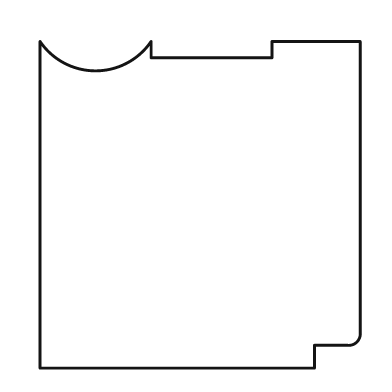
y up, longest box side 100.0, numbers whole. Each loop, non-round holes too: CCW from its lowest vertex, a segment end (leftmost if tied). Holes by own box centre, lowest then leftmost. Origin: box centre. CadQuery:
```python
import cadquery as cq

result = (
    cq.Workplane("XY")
    .moveTo(-49.0, -50.0)
    .lineTo(35.0, -50.0)
    .lineTo(35.0, -43.0)
    .lineTo(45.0, -43.0)
    .threePointArc((48.0, -42.0), (49.0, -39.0))
    .lineTo(49.0, 50.0)
    .lineTo(22.0, 50.0)
    .lineTo(22.0, 45.0)
    .lineTo(-15.0, 45.0)
    .lineTo(-15.0, 50.0)
    .threePointArc((-32.0, 41.0), (-49.0, 50.0))
    .close()
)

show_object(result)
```